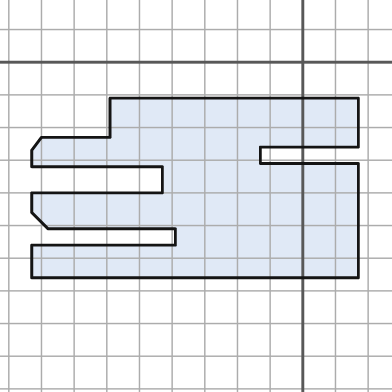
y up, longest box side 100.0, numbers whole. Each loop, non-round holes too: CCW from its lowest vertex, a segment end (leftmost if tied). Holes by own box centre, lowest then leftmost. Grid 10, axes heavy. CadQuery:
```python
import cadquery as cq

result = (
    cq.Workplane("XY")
    .moveTo(-83.0, -66.0)
    .lineTo(17.0, -66.0)
    .lineTo(17.0, -31.0)
    .lineTo(-13.0, -31.0)
    .lineTo(-13.0, -26.0)
    .lineTo(17.0, -26.0)
    .lineTo(17.0, -11.0)
    .lineTo(-59.0, -11.0)
    .lineTo(-59.0, -23.0)
    .lineTo(-80.0, -23.0)
    .lineTo(-83.0, -27.0)
    .lineTo(-83.0, -32.0)
    .lineTo(-43.0, -32.0)
    .lineTo(-43.0, -40.0)
    .lineTo(-83.0, -40.0)
    .lineTo(-83.0, -46.0)
    .lineTo(-78.0, -51.0)
    .lineTo(-39.0, -51.0)
    .lineTo(-39.0, -56.0)
    .lineTo(-83.0, -56.0)
    .close()
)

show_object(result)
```